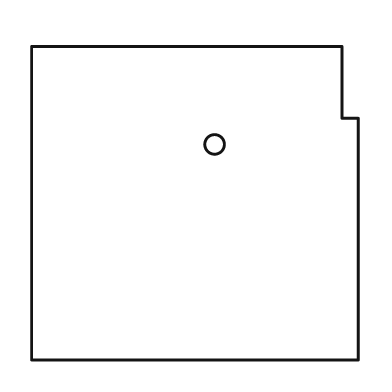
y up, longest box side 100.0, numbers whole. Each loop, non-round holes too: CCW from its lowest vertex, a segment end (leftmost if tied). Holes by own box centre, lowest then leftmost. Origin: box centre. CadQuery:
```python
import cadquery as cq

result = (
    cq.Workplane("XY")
    .moveTo(-50.0, -48.0)
    .lineTo(50.0, -48.0)
    .lineTo(50.0, 26.0)
    .lineTo(45.0, 26.0)
    .lineTo(45.0, 48.0)
    .lineTo(-50.0, 48.0)
    .close()
    .moveTo(6.0, 18.0)
    .circle(3.0)
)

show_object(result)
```